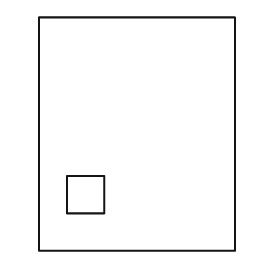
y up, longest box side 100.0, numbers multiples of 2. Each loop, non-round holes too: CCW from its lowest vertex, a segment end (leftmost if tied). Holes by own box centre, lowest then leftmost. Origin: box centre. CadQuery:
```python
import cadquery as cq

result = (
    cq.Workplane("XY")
    .moveTo(-42.0, -50.0)
    .lineTo(42.0, -50.0)
    .lineTo(42.0, 50.0)
    .lineTo(-42.0, 50.0)
    .close()
    .moveTo(-30.0, -34.0)
    .lineTo(-14.0, -34.0)
    .lineTo(-14.0, -18.0)
    .lineTo(-30.0, -18.0)
    .close()
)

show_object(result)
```